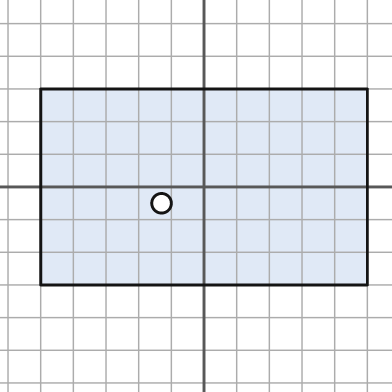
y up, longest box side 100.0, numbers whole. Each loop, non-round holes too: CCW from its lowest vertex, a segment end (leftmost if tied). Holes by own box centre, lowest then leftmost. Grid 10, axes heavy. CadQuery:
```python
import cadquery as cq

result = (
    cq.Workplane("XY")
    .moveTo(-50.0, -30.0)
    .lineTo(50.0, -30.0)
    .lineTo(50.0, 30.0)
    .lineTo(-50.0, 30.0)
    .close()
    .moveTo(-13.0, -5.0)
    .circle(3.0)
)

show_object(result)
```